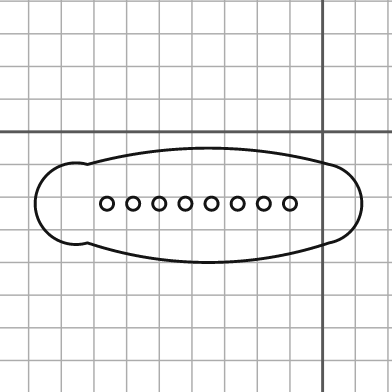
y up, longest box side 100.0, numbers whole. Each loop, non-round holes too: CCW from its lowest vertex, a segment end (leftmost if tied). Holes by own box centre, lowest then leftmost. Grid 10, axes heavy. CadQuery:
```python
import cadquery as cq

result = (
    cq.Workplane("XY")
    .moveTo(-72.0, -34.0)
    .threePointArc((-35.0, -40.0), (2.0, -34.0))
    .threePointArc((12.0, -22.0), (2.0, -10.0))
    .threePointArc((-35.0, -5.0), (-72.0, -10.0))
    .threePointArc((-88.0, -22.0), (-72.0, -34.0))
    .close()
    .moveTo(-66.0, -22.0)
    .circle(2.0)
    .moveTo(-58.0, -22.0)
    .circle(2.0)
    .moveTo(-50.0, -22.0)
    .circle(2.0)
    .moveTo(-42.0, -22.0)
    .circle(2.0)
    .moveTo(-34.0, -22.0)
    .circle(2.0)
    .moveTo(-26.0, -22.0)
    .circle(2.0)
    .moveTo(-18.0, -22.0)
    .circle(2.0)
    .moveTo(-10.0, -22.0)
    .circle(2.0)
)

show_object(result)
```